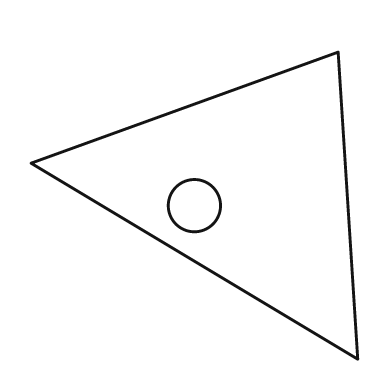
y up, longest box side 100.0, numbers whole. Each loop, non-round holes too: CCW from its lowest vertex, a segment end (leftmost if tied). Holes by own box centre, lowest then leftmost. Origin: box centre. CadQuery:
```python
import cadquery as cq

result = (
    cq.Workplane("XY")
    .moveTo(50.0, -47.0)
    .lineTo(44.0, 47.0)
    .lineTo(-50.0, 13.0)
    .close()
    .moveTo(0.0, 0.0)
    .circle(8.0)
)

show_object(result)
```